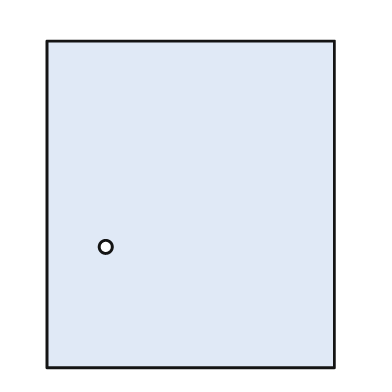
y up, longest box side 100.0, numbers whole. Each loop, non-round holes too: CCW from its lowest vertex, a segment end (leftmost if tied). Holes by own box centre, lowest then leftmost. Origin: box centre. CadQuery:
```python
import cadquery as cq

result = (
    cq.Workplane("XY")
    .moveTo(-44.0, -50.0)
    .lineTo(44.0, -50.0)
    .lineTo(44.0, 50.0)
    .lineTo(-44.0, 50.0)
    .close()
    .moveTo(-26.0, -13.0)
    .circle(2.0)
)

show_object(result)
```